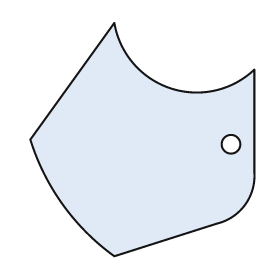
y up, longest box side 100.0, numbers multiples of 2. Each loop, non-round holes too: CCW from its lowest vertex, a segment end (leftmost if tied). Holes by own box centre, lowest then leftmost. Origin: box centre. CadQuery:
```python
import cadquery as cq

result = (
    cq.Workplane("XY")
    .moveTo(-12.0, -50.0)
    .lineTo(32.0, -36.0)
    .threePointArc((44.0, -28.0), (48.0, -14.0))
    .lineTo(48.0, 30.0)
    .threePointArc((12.0, 22.0), (-12.0, 50.0))
    .lineTo(-48.0, 0.0)
    .threePointArc((-34.0, -28.0), (-12.0, -50.0))
    .close()
    .moveTo(38.0, -2.0)
    .circle(4.0)
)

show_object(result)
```